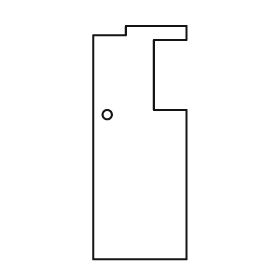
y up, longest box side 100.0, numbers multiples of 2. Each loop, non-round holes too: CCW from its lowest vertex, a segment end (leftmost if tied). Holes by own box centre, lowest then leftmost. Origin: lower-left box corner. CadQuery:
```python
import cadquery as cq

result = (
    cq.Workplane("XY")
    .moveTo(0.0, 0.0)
    .lineTo(40.0, 0.0)
    .lineTo(40.0, 64.0)
    .lineTo(26.0, 64.0)
    .lineTo(26.0, 94.0)
    .lineTo(40.0, 94.0)
    .lineTo(40.0, 100.0)
    .lineTo(14.0, 100.0)
    .lineTo(14.0, 96.0)
    .lineTo(0.0, 96.0)
    .close()
    .moveTo(6.0, 62.0)
    .circle(2.0)
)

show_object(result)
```